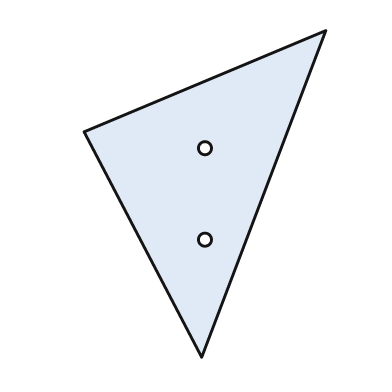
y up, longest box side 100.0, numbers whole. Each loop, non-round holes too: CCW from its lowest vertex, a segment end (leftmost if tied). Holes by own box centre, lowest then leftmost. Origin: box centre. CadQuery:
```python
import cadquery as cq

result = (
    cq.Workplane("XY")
    .moveTo(-1.0, -50.0)
    .lineTo(37.0, 50.0)
    .lineTo(-37.0, 19.0)
    .close()
    .moveTo(0.0, -14.0)
    .circle(2.0)
    .moveTo(0.0, 14.0)
    .circle(2.0)
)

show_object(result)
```